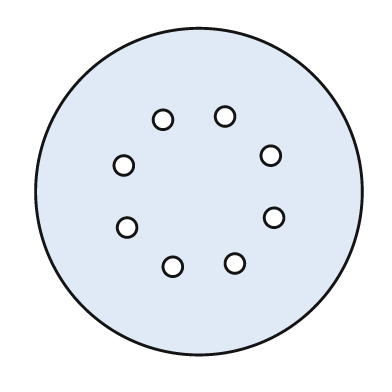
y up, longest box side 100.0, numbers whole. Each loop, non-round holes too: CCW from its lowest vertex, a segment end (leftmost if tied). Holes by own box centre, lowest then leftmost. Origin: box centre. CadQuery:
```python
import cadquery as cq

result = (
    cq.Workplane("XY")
    .moveTo(0.0, 0.0)
    .circle(50.0)
    .moveTo(-8.0, -23.0)
    .circle(3.0)
    .moveTo(11.0, -22.0)
    .circle(3.0)
    .moveTo(-22.0, -11.0)
    .circle(3.0)
    .moveTo(23.0, -8.0)
    .circle(3.0)
    .moveTo(-23.0, 8.0)
    .circle(3.0)
    .moveTo(22.0, 11.0)
    .circle(3.0)
    .moveTo(-11.0, 22.0)
    .circle(3.0)
    .moveTo(8.0, 23.0)
    .circle(3.0)
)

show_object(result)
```